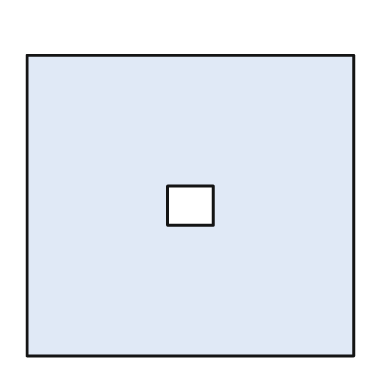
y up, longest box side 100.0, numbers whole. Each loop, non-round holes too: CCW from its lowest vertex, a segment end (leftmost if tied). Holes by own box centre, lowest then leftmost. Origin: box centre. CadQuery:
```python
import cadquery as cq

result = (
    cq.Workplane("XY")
    .moveTo(-50.0, -46.0)
    .lineTo(50.0, -46.0)
    .lineTo(50.0, 46.0)
    .lineTo(-50.0, 46.0)
    .close()
    .moveTo(-7.0, -6.0)
    .lineTo(7.0, -6.0)
    .lineTo(7.0, 6.0)
    .lineTo(-7.0, 6.0)
    .close()
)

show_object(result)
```